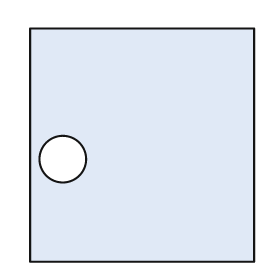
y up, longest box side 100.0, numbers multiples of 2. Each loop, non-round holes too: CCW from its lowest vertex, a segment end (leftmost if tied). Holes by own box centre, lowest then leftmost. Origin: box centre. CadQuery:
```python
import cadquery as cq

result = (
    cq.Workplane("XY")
    .moveTo(-48.0, -50.0)
    .lineTo(48.0, -50.0)
    .lineTo(48.0, 50.0)
    .lineTo(-48.0, 50.0)
    .close()
    .moveTo(-34.0, -6.0)
    .circle(10.0)
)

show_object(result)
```